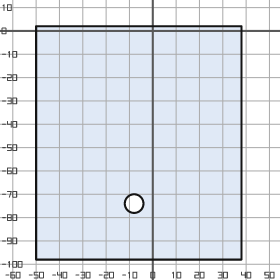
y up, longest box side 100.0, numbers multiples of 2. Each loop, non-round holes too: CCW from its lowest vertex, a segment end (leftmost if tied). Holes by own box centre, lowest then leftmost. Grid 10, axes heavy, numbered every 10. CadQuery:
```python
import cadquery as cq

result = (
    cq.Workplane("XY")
    .moveTo(-50.0, -98.0)
    .lineTo(38.0, -98.0)
    .lineTo(38.0, 2.0)
    .lineTo(-50.0, 2.0)
    .close()
    .moveTo(-8.0, -74.0)
    .circle(4.0)
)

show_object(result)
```